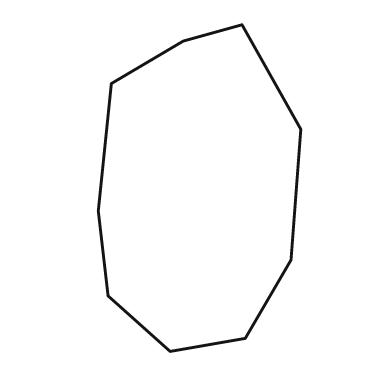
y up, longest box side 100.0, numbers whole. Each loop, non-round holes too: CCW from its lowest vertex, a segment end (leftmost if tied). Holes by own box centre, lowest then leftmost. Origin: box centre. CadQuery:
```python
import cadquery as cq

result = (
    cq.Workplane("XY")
    .moveTo(-9.0, -50.0)
    .lineTo(14.0, -46.0)
    .lineTo(28.0, -22.0)
    .lineTo(31.0, 18.0)
    .lineTo(13.0, 50.0)
    .lineTo(-5.0, 45.0)
    .lineTo(-27.0, 32.0)
    .lineTo(-31.0, -7.0)
    .lineTo(-28.0, -33.0)
    .close()
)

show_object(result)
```